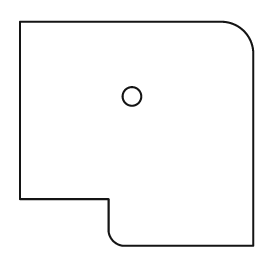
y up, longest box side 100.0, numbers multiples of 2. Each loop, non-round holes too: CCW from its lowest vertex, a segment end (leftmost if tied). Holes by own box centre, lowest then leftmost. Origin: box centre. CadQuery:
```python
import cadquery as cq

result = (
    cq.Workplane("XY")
    .moveTo(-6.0, -48.0)
    .lineTo(50.0, -48.0)
    .lineTo(50.0, 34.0)
    .threePointArc((46.0, 44.0), (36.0, 48.0))
    .lineTo(-50.0, 48.0)
    .lineTo(-50.0, -28.0)
    .lineTo(-12.0, -28.0)
    .lineTo(-12.0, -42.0)
    .threePointArc((-10.0, -46.0), (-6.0, -48.0))
    .close()
    .moveTo(-2.0, 16.0)
    .circle(4.0)
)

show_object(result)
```